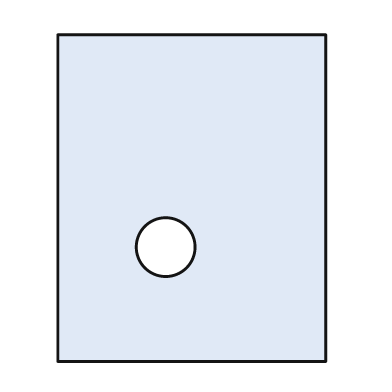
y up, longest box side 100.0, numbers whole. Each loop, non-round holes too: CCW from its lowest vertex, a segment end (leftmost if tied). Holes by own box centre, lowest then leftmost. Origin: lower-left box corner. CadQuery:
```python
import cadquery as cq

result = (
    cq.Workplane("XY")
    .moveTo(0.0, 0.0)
    .lineTo(82.0, 0.0)
    .lineTo(82.0, 100.0)
    .lineTo(0.0, 100.0)
    .close()
    .moveTo(33.0, 35.0)
    .circle(9.0)
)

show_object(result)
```